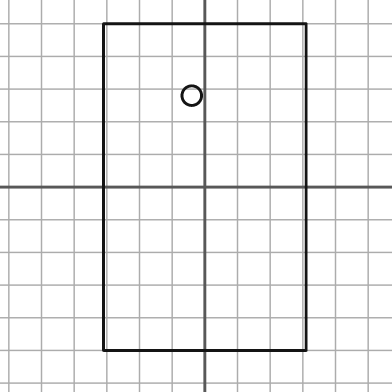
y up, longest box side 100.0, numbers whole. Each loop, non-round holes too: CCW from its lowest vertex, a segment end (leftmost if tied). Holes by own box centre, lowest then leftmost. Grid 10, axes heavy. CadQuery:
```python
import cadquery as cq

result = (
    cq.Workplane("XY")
    .moveTo(-31.0, -50.0)
    .lineTo(31.0, -50.0)
    .lineTo(31.0, 50.0)
    .lineTo(-31.0, 50.0)
    .close()
    .moveTo(-4.0, 28.0)
    .circle(3.0)
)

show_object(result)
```